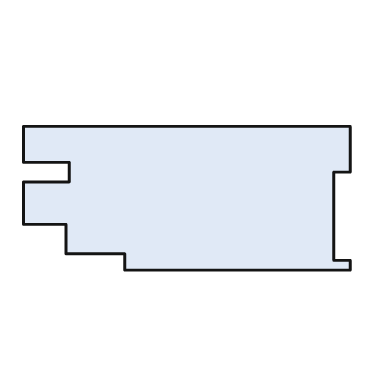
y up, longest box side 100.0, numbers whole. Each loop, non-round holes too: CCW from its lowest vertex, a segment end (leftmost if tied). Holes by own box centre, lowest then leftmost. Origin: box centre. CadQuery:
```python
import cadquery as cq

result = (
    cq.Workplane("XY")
    .moveTo(-19.0, -22.0)
    .lineTo(50.0, -22.0)
    .lineTo(50.0, -19.0)
    .lineTo(45.0, -19.0)
    .lineTo(45.0, 8.0)
    .lineTo(50.0, 8.0)
    .lineTo(50.0, 22.0)
    .lineTo(-50.0, 22.0)
    .lineTo(-50.0, 11.0)
    .lineTo(-36.0, 11.0)
    .lineTo(-36.0, 5.0)
    .lineTo(-50.0, 5.0)
    .lineTo(-50.0, -8.0)
    .lineTo(-37.0, -8.0)
    .lineTo(-37.0, -17.0)
    .lineTo(-19.0, -17.0)
    .close()
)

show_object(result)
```